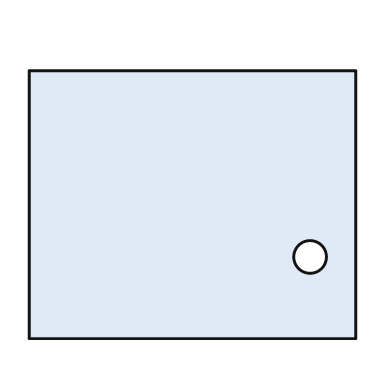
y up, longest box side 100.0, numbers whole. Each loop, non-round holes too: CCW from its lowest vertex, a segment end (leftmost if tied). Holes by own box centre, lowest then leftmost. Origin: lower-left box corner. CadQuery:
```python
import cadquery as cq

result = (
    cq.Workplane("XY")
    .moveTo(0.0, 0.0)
    .lineTo(100.0, 0.0)
    .lineTo(100.0, 82.0)
    .lineTo(0.0, 82.0)
    .close()
    .moveTo(86.0, 25.0)
    .circle(5.0)
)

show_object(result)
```